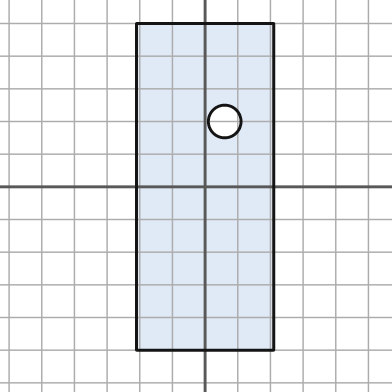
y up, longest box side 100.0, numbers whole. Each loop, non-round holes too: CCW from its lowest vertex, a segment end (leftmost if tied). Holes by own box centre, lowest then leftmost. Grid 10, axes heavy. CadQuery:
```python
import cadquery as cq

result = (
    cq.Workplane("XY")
    .moveTo(-21.0, -50.0)
    .lineTo(21.0, -50.0)
    .lineTo(21.0, 50.0)
    .lineTo(-21.0, 50.0)
    .close()
    .moveTo(6.0, 20.0)
    .circle(5.0)
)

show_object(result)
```